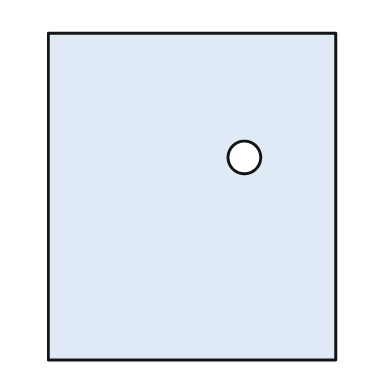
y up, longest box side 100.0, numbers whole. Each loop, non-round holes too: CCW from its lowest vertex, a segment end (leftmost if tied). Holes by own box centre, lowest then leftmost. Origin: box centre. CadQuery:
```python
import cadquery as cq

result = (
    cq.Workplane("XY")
    .moveTo(-44.0, -50.0)
    .lineTo(44.0, -50.0)
    .lineTo(44.0, 50.0)
    .lineTo(-44.0, 50.0)
    .close()
    .moveTo(16.0, 12.0)
    .circle(5.0)
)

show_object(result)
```